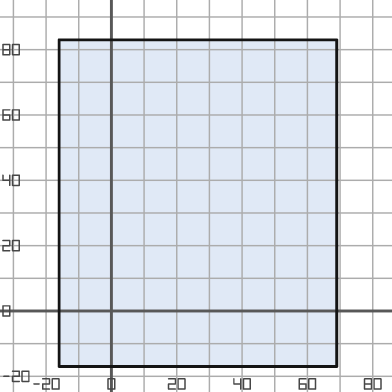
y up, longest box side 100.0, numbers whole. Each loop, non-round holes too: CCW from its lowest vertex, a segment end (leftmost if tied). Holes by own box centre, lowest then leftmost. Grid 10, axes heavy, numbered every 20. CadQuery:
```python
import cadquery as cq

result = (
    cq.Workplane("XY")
    .moveTo(-16.0, -17.0)
    .lineTo(69.0, -17.0)
    .lineTo(69.0, 83.0)
    .lineTo(-16.0, 83.0)
    .close()
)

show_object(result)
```